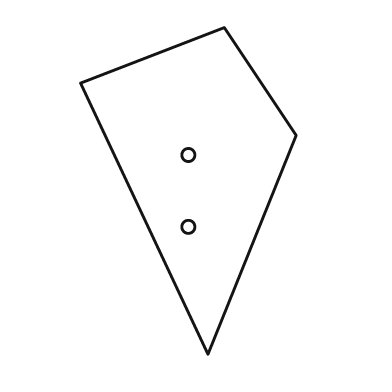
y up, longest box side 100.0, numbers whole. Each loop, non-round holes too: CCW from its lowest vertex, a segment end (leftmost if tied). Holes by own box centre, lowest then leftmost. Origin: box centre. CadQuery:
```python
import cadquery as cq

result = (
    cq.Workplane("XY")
    .moveTo(6.0, -50.0)
    .lineTo(33.0, 17.0)
    .lineTo(11.0, 50.0)
    .lineTo(-33.0, 33.0)
    .close()
    .moveTo(0.0, -11.0)
    .circle(2.0)
    .moveTo(0.0, 11.0)
    .circle(2.0)
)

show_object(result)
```